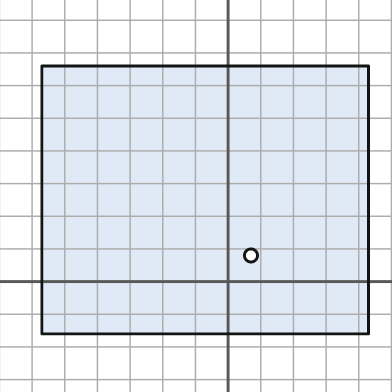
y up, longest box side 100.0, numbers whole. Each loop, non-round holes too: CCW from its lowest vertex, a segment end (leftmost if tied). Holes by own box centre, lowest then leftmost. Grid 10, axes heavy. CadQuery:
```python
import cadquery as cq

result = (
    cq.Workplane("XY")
    .moveTo(-57.0, -16.0)
    .lineTo(43.0, -16.0)
    .lineTo(43.0, 66.0)
    .lineTo(-57.0, 66.0)
    .close()
    .moveTo(7.0, 8.0)
    .circle(2.0)
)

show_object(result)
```